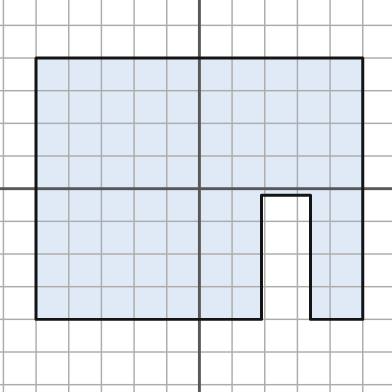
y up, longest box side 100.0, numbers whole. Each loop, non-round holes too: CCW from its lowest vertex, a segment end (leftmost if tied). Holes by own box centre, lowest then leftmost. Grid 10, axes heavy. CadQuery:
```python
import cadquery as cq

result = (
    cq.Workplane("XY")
    .moveTo(-50.0, -40.0)
    .lineTo(19.0, -40.0)
    .lineTo(19.0, -2.0)
    .lineTo(34.0, -2.0)
    .lineTo(34.0, -40.0)
    .lineTo(50.0, -40.0)
    .lineTo(50.0, 40.0)
    .lineTo(-50.0, 40.0)
    .close()
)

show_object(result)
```